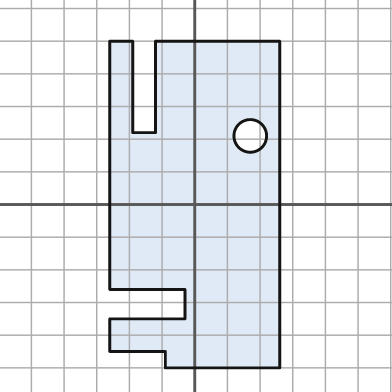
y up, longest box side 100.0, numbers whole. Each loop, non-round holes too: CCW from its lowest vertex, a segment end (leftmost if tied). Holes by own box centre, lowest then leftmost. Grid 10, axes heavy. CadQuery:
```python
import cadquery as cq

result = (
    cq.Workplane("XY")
    .moveTo(-9.0, -50.0)
    .lineTo(26.0, -50.0)
    .lineTo(26.0, 50.0)
    .lineTo(-12.0, 50.0)
    .lineTo(-12.0, 22.0)
    .lineTo(-19.0, 22.0)
    .lineTo(-19.0, 50.0)
    .lineTo(-26.0, 50.0)
    .lineTo(-26.0, -26.0)
    .lineTo(-3.0, -26.0)
    .lineTo(-3.0, -35.0)
    .lineTo(-26.0, -35.0)
    .lineTo(-26.0, -45.0)
    .lineTo(-9.0, -45.0)
    .close()
    .moveTo(17.0, 21.0)
    .circle(5.0)
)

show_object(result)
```